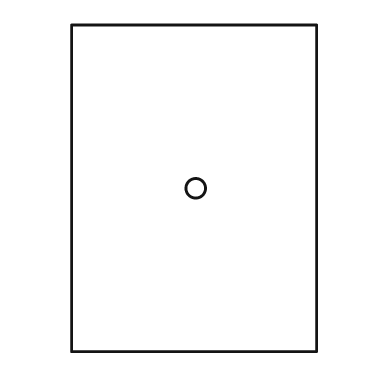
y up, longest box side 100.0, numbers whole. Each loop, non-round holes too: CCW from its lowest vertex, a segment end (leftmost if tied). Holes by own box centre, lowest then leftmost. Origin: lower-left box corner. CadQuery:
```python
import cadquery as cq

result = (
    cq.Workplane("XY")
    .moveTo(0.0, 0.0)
    .lineTo(75.0, 0.0)
    .lineTo(75.0, 100.0)
    .lineTo(0.0, 100.0)
    .close()
    .moveTo(38.0, 50.0)
    .circle(3.0)
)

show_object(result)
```